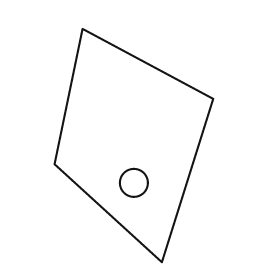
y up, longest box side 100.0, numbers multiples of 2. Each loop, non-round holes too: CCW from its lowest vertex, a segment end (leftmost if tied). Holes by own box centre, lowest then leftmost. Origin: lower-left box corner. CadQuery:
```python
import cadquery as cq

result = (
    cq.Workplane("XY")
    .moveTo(46.0, 0.0)
    .lineTo(68.0, 70.0)
    .lineTo(12.0, 100.0)
    .lineTo(0.0, 42.0)
    .close()
    .moveTo(34.0, 34.0)
    .circle(6.0)
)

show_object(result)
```